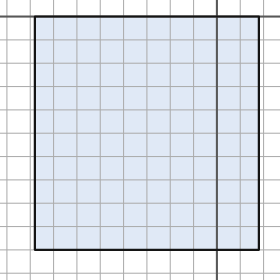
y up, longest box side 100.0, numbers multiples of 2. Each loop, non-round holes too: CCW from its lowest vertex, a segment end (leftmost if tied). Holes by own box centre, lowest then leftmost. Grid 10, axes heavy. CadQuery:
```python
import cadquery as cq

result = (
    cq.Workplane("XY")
    .moveTo(-78.0, -100.0)
    .lineTo(18.0, -100.0)
    .lineTo(18.0, 0.0)
    .lineTo(-78.0, 0.0)
    .close()
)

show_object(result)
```